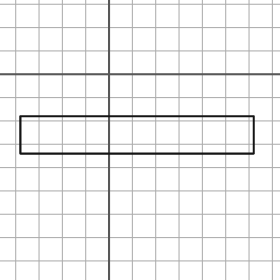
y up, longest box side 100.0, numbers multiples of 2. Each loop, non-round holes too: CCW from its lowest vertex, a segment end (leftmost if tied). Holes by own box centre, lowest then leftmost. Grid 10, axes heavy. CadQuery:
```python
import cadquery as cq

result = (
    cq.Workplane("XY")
    .moveTo(-38.0, -34.0)
    .lineTo(62.0, -34.0)
    .lineTo(62.0, -18.0)
    .lineTo(-38.0, -18.0)
    .close()
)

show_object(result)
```